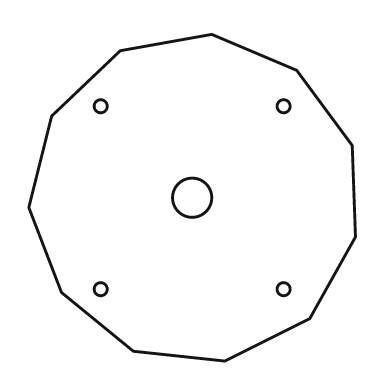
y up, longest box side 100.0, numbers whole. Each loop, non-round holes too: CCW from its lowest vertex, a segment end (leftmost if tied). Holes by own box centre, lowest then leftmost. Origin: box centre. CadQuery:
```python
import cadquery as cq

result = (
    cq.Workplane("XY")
    .moveTo(10.0, -50.0)
    .lineTo(36.0, -37.0)
    .lineTo(50.0, -12.0)
    .lineTo(49.0, 16.0)
    .lineTo(32.0, 39.0)
    .lineTo(6.0, 50.0)
    .lineTo(-22.0, 45.0)
    .lineTo(-43.0, 25.0)
    .lineTo(-50.0, -3.0)
    .lineTo(-40.0, -29.0)
    .lineTo(-18.0, -47.0)
    .close()
    .moveTo(-28.0, -28.0)
    .circle(2.0)
    .moveTo(28.0, -28.0)
    .circle(2.0)
    .moveTo(0.0, 0.0)
    .circle(6.0)
    .moveTo(-28.0, 28.0)
    .circle(2.0)
    .moveTo(28.0, 28.0)
    .circle(2.0)
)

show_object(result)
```